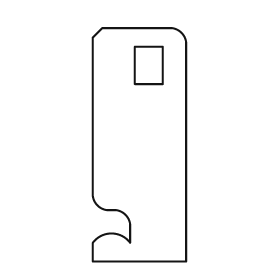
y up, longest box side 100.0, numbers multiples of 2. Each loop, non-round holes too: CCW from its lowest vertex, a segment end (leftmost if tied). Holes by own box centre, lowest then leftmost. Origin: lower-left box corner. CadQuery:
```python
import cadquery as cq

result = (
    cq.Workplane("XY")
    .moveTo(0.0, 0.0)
    .lineTo(40.0, 0.0)
    .lineTo(40.0, 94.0)
    .threePointArc((38.0, 98.0), (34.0, 100.0))
    .lineTo(4.0, 100.0)
    .lineTo(0.0, 96.0)
    .lineTo(0.0, 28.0)
    .threePointArc((2.0, 24.0), (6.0, 22.0))
    .lineTo(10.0, 22.0)
    .threePointArc((14.0, 20.0), (16.0, 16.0))
    .lineTo(16.0, 8.0)
    .threePointArc((8.0, 12.0), (0.0, 8.0))
    .close()
    .moveTo(18.0, 76.0)
    .lineTo(30.0, 76.0)
    .lineTo(30.0, 92.0)
    .lineTo(18.0, 92.0)
    .close()
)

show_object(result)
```